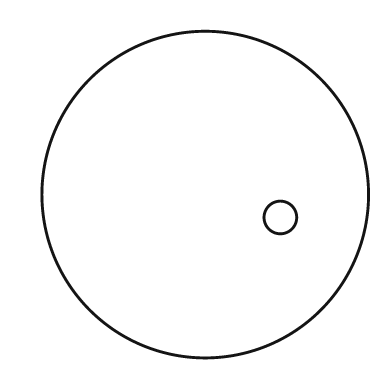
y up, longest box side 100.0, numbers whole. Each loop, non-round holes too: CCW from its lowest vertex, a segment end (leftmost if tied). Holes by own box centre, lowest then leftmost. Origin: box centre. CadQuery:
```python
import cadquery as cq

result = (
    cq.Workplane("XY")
    .moveTo(0.0, 0.0)
    .circle(50.0)
    .moveTo(23.0, -7.0)
    .circle(5.0)
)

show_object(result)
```